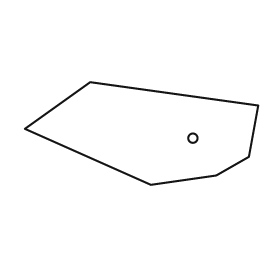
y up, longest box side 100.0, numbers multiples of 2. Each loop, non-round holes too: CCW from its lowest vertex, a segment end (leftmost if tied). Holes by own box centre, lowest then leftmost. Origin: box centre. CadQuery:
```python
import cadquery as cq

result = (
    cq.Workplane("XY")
    .moveTo(4.0, -22.0)
    .lineTo(32.0, -18.0)
    .lineTo(46.0, -10.0)
    .lineTo(50.0, 12.0)
    .lineTo(-22.0, 22.0)
    .lineTo(-50.0, 2.0)
    .close()
    .moveTo(22.0, -2.0)
    .circle(2.0)
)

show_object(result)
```